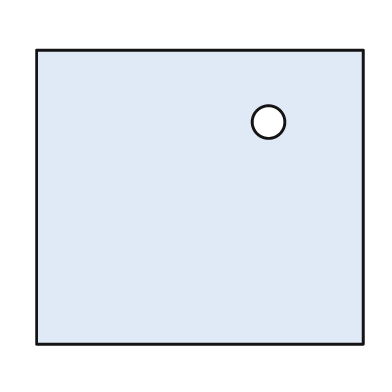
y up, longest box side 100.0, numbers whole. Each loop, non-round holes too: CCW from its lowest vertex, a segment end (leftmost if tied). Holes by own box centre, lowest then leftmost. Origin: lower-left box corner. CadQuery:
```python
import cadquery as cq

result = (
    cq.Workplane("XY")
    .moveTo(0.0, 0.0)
    .lineTo(100.0, 0.0)
    .lineTo(100.0, 90.0)
    .lineTo(0.0, 90.0)
    .close()
    .moveTo(71.0, 68.0)
    .circle(5.0)
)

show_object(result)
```